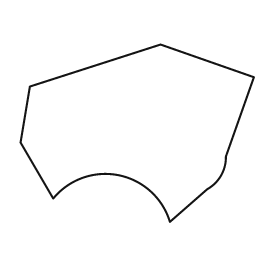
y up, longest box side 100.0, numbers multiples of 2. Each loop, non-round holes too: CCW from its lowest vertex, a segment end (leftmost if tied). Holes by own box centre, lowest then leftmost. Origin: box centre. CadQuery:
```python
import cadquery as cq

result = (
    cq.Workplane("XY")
    .moveTo(14.0, -38.0)
    .lineTo(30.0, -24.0)
    .threePointArc((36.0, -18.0), (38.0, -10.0))
    .lineTo(50.0, 24.0)
    .lineTo(10.0, 38.0)
    .lineTo(-46.0, 20.0)
    .lineTo(-50.0, -4.0)
    .lineTo(-36.0, -28.0)
    .threePointArc((-8.0, -18.0), (14.0, -38.0))
    .close()
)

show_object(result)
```